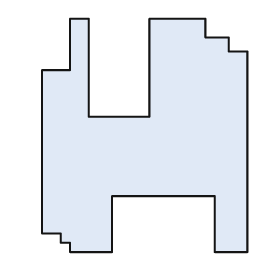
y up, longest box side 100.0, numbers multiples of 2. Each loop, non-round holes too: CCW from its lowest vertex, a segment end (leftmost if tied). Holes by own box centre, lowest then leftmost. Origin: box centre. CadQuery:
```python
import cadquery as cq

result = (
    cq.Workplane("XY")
    .moveTo(-32.0, -50.0)
    .lineTo(-14.0, -50.0)
    .lineTo(-14.0, -26.0)
    .lineTo(30.0, -26.0)
    .lineTo(30.0, -50.0)
    .lineTo(44.0, -50.0)
    .lineTo(44.0, 36.0)
    .lineTo(36.0, 36.0)
    .lineTo(36.0, 42.0)
    .lineTo(26.0, 42.0)
    .lineTo(26.0, 50.0)
    .lineTo(2.0, 50.0)
    .lineTo(2.0, 8.0)
    .lineTo(-24.0, 8.0)
    .lineTo(-24.0, 50.0)
    .lineTo(-32.0, 50.0)
    .lineTo(-32.0, 28.0)
    .lineTo(-44.0, 28.0)
    .lineTo(-44.0, -42.0)
    .lineTo(-36.0, -42.0)
    .lineTo(-36.0, -46.0)
    .lineTo(-32.0, -46.0)
    .close()
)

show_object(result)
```